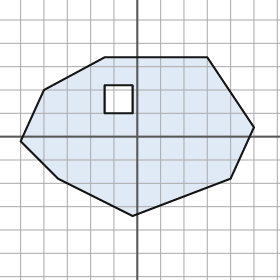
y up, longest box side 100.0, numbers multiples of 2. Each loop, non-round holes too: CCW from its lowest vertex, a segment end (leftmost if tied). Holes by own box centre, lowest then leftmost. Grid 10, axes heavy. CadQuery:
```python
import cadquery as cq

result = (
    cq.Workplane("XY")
    .moveTo(-2.0, -34.0)
    .lineTo(40.0, -18.0)
    .lineTo(50.0, 4.0)
    .lineTo(30.0, 34.0)
    .lineTo(-14.0, 34.0)
    .lineTo(-40.0, 20.0)
    .lineTo(-50.0, -2.0)
    .lineTo(-34.0, -18.0)
    .close()
    .moveTo(-14.0, 10.0)
    .lineTo(-2.0, 10.0)
    .lineTo(-2.0, 22.0)
    .lineTo(-14.0, 22.0)
    .close()
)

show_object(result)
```